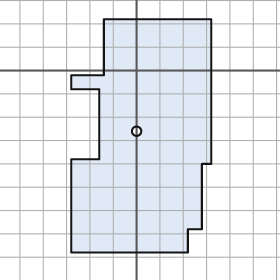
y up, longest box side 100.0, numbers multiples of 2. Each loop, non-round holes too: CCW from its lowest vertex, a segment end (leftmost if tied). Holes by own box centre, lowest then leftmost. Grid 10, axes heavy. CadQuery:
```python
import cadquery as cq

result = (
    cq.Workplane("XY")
    .moveTo(-28.0, -78.0)
    .lineTo(22.0, -78.0)
    .lineTo(22.0, -68.0)
    .lineTo(28.0, -68.0)
    .lineTo(28.0, -40.0)
    .lineTo(32.0, -40.0)
    .lineTo(32.0, 22.0)
    .lineTo(-14.0, 22.0)
    .lineTo(-14.0, -2.0)
    .lineTo(-28.0, -2.0)
    .lineTo(-28.0, -8.0)
    .lineTo(-16.0, -8.0)
    .lineTo(-16.0, -38.0)
    .lineTo(-28.0, -38.0)
    .close()
    .moveTo(0.0, -26.0)
    .circle(2.0)
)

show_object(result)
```